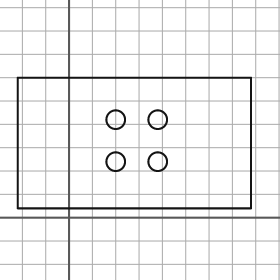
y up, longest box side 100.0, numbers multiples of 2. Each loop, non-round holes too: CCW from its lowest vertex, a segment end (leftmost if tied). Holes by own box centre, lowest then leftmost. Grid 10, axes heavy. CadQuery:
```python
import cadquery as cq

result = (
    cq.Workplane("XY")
    .moveTo(-22.0, 4.0)
    .lineTo(78.0, 4.0)
    .lineTo(78.0, 60.0)
    .lineTo(-22.0, 60.0)
    .close()
    .moveTo(20.0, 24.0)
    .circle(4.0)
    .moveTo(38.0, 24.0)
    .circle(4.0)
    .moveTo(20.0, 42.0)
    .circle(4.0)
    .moveTo(38.0, 42.0)
    .circle(4.0)
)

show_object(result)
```